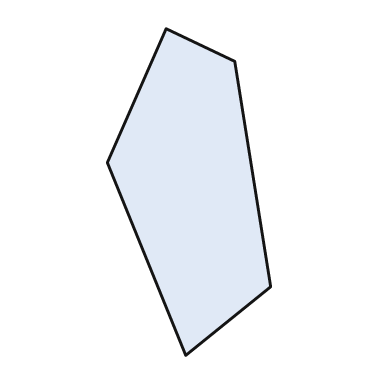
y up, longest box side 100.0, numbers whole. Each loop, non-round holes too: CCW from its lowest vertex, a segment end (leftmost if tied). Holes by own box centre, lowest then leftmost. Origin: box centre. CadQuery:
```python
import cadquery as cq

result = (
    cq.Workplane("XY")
    .moveTo(-1.0, -50.0)
    .lineTo(25.0, -29.0)
    .lineTo(14.0, 40.0)
    .lineTo(-7.0, 50.0)
    .lineTo(-25.0, 9.0)
    .close()
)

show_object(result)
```